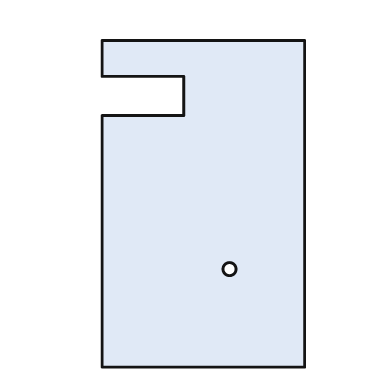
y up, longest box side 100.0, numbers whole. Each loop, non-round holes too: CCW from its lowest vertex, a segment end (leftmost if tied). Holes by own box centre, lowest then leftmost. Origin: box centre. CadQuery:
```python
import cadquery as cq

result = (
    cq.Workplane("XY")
    .moveTo(-31.0, -50.0)
    .lineTo(31.0, -50.0)
    .lineTo(31.0, 50.0)
    .lineTo(-31.0, 50.0)
    .lineTo(-31.0, 39.0)
    .lineTo(-6.0, 39.0)
    .lineTo(-6.0, 27.0)
    .lineTo(-31.0, 27.0)
    .close()
    .moveTo(8.0, -20.0)
    .circle(2.0)
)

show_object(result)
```